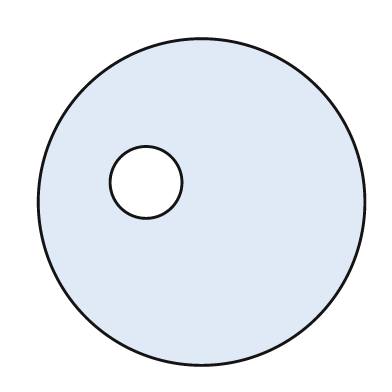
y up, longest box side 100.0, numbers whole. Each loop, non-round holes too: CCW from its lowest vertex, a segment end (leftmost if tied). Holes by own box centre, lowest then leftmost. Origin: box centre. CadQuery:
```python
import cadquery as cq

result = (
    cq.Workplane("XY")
    .moveTo(0.0, 0.0)
    .circle(50.0)
    .moveTo(-17.0, 6.0)
    .circle(11.0)
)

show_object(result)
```